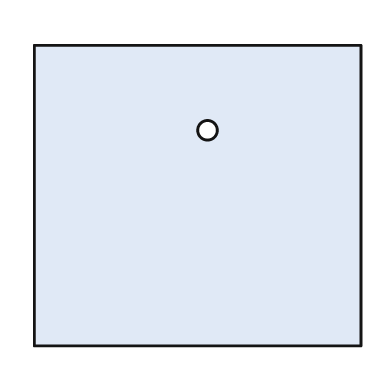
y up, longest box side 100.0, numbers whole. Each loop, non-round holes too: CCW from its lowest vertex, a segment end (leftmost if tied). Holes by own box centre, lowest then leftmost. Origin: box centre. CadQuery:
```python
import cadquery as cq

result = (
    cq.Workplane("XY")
    .moveTo(-50.0, -46.0)
    .lineTo(50.0, -46.0)
    .lineTo(50.0, 46.0)
    .lineTo(-50.0, 46.0)
    .close()
    .moveTo(3.0, 20.0)
    .circle(3.0)
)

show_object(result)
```